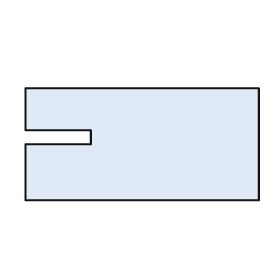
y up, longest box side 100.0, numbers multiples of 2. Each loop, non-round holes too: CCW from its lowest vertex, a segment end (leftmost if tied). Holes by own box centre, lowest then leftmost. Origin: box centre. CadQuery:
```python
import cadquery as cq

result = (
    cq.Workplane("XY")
    .moveTo(-50.0, -24.0)
    .lineTo(50.0, -24.0)
    .lineTo(50.0, 24.0)
    .lineTo(-50.0, 24.0)
    .lineTo(-50.0, 6.0)
    .lineTo(-22.0, 6.0)
    .lineTo(-22.0, 0.0)
    .lineTo(-50.0, 0.0)
    .close()
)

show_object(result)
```